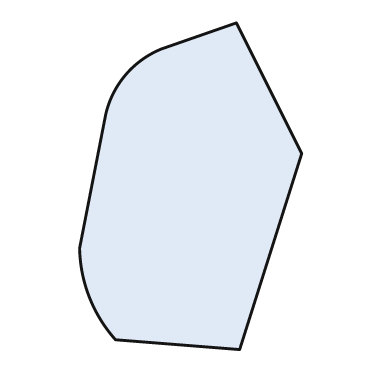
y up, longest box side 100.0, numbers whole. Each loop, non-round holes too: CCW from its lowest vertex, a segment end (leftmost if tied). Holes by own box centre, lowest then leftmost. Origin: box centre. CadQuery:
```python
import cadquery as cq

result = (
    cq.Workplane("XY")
    .moveTo(15.0, -50.0)
    .lineTo(34.0, 10.0)
    .lineTo(14.0, 50.0)
    .lineTo(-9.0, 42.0)
    .threePointArc((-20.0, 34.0), (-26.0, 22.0))
    .lineTo(-34.0, -19.0)
    .threePointArc((-31.0, -34.0), (-23.0, -47.0))
    .close()
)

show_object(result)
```